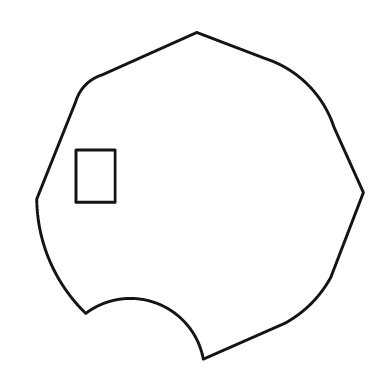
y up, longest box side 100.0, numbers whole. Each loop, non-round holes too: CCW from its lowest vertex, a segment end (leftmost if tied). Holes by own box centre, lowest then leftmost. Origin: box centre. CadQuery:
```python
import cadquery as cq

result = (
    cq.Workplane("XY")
    .moveTo(1.0, -50.0)
    .lineTo(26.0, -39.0)
    .threePointArc((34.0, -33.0), (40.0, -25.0))
    .lineTo(50.0, 1.0)
    .lineTo(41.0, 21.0)
    .threePointArc((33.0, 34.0), (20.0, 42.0))
    .lineTo(-1.0, 50.0)
    .lineTo(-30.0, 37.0)
    .threePointArc((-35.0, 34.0), (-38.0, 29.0))
    .lineTo(-50.0, -1.0)
    .threePointArc((-46.0, -20.0), (-35.0, -36.0))
    .threePointArc((-13.0, -33.0), (1.0, -50.0))
    .close()
    .moveTo(-38.0, -2.0)
    .lineTo(-26.0, -2.0)
    .lineTo(-26.0, 14.0)
    .lineTo(-38.0, 14.0)
    .close()
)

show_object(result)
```